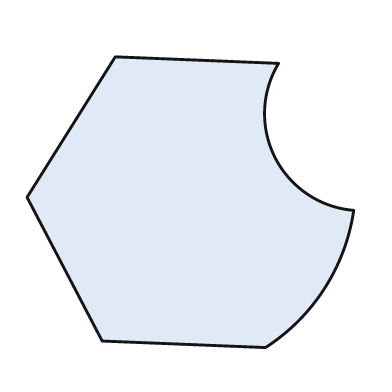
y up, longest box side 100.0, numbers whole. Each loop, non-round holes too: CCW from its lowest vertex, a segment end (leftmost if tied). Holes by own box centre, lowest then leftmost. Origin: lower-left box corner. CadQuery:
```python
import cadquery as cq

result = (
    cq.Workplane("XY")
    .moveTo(73.0, 0.0)
    .threePointArc((91.0, 18.0), (100.0, 42.0))
    .threePointArc((76.0, 58.0), (77.0, 87.0))
    .lineTo(27.0, 89.0)
    .lineTo(0.0, 46.0)
    .lineTo(23.0, 2.0)
    .close()
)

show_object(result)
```